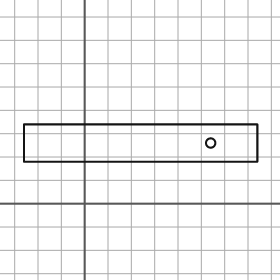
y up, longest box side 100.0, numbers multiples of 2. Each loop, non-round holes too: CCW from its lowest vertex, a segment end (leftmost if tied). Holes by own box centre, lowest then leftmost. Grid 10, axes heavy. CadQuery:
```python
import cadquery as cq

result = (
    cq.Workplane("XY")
    .moveTo(-26.0, 18.0)
    .lineTo(74.0, 18.0)
    .lineTo(74.0, 34.0)
    .lineTo(-26.0, 34.0)
    .close()
    .moveTo(54.0, 26.0)
    .circle(2.0)
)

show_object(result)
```